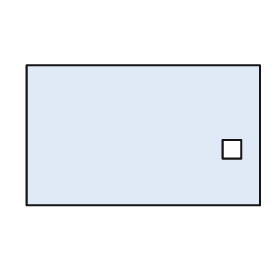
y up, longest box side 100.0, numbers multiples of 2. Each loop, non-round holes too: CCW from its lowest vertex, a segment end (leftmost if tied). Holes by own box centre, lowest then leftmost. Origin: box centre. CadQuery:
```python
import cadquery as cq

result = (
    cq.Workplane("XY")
    .moveTo(-50.0, -30.0)
    .lineTo(50.0, -30.0)
    .lineTo(50.0, 30.0)
    .lineTo(-50.0, 30.0)
    .close()
    .moveTo(34.0, -10.0)
    .lineTo(42.0, -10.0)
    .lineTo(42.0, -2.0)
    .lineTo(34.0, -2.0)
    .close()
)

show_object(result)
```